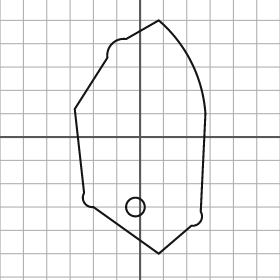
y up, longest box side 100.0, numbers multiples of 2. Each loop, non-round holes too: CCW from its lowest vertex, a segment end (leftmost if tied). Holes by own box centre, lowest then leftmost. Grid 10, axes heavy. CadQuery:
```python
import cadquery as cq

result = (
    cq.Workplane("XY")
    .moveTo(8.0, -50.0)
    .lineTo(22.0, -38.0)
    .threePointArc((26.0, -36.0), (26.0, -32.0))
    .lineTo(28.0, 10.0)
    .threePointArc((22.0, 32.0), (8.0, 50.0))
    .lineTo(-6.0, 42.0)
    .threePointArc((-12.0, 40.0), (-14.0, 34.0))
    .lineTo(-28.0, 12.0)
    .lineTo(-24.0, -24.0)
    .threePointArc((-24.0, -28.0), (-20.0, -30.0))
    .close()
    .moveTo(-2.0, -30.0)
    .circle(4.0)
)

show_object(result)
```